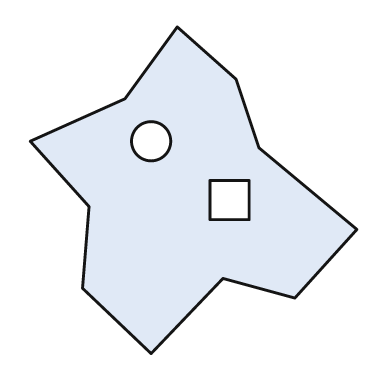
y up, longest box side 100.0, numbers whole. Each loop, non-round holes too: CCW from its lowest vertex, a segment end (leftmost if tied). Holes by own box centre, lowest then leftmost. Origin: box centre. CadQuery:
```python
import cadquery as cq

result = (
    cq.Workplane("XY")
    .moveTo(-13.0, -50.0)
    .lineTo(9.0, -27.0)
    .lineTo(31.0, -33.0)
    .lineTo(50.0, -12.0)
    .lineTo(20.0, 13.0)
    .lineTo(13.0, 34.0)
    .lineTo(-5.0, 50.0)
    .lineTo(-21.0, 28.0)
    .lineTo(-50.0, 15.0)
    .lineTo(-32.0, -5.0)
    .lineTo(-34.0, -30.0)
    .close()
    .moveTo(5.0, -9.0)
    .lineTo(17.0, -9.0)
    .lineTo(17.0, 3.0)
    .lineTo(5.0, 3.0)
    .close()
    .moveTo(-13.0, 15.0)
    .circle(6.0)
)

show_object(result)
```